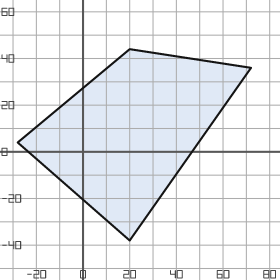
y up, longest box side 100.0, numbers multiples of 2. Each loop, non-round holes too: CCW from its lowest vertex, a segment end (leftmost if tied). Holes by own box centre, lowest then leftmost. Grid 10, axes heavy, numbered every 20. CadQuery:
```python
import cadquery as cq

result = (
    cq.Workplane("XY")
    .moveTo(20.0, -38.0)
    .lineTo(72.0, 36.0)
    .lineTo(20.0, 44.0)
    .lineTo(-28.0, 4.0)
    .close()
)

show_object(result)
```